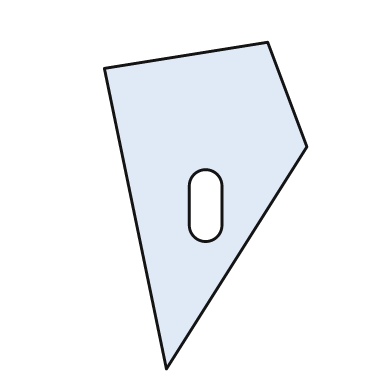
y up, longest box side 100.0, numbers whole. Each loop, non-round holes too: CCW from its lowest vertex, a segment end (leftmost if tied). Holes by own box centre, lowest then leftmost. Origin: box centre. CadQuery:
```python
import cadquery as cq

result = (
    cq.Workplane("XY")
    .moveTo(-12.0, -50.0)
    .lineTo(31.0, 18.0)
    .lineTo(19.0, 50.0)
    .lineTo(-31.0, 42.0)
    .close()
    .moveTo(-5.0, -6.0)
    .threePointArc((0.0, -11.0), (5.0, -6.0))
    .lineTo(5.0, 6.0)
    .threePointArc((0.0, 11.0), (-5.0, 6.0))
    .close()
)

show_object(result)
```